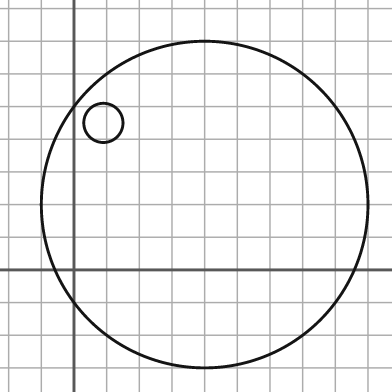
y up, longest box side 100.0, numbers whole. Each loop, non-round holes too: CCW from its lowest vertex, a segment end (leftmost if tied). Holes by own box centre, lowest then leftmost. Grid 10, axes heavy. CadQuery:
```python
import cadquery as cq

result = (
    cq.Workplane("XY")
    .moveTo(40.0, 20.0)
    .circle(50.0)
    .moveTo(9.0, 45.0)
    .circle(6.0)
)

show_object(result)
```